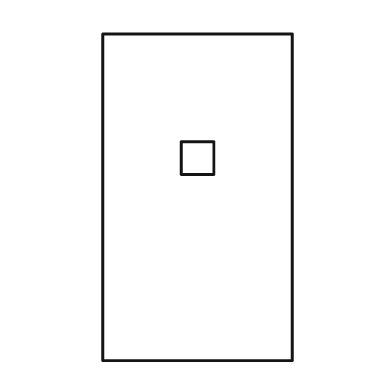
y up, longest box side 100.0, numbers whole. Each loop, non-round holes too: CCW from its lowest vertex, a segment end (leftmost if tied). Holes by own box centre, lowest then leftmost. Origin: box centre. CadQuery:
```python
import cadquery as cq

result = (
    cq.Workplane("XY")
    .moveTo(-29.0, -50.0)
    .lineTo(29.0, -50.0)
    .lineTo(29.0, 50.0)
    .lineTo(-29.0, 50.0)
    .close()
    .moveTo(-5.0, 7.0)
    .lineTo(5.0, 7.0)
    .lineTo(5.0, 17.0)
    .lineTo(-5.0, 17.0)
    .close()
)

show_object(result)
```